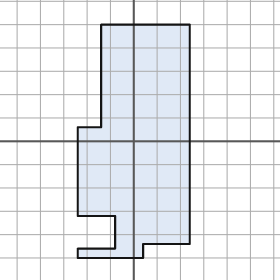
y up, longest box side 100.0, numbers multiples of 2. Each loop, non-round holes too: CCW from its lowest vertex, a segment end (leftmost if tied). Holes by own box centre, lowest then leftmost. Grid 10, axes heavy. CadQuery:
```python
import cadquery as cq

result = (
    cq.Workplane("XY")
    .moveTo(-24.0, -50.0)
    .lineTo(4.0, -50.0)
    .lineTo(4.0, -44.0)
    .lineTo(24.0, -44.0)
    .lineTo(24.0, 50.0)
    .lineTo(-14.0, 50.0)
    .lineTo(-14.0, 6.0)
    .lineTo(-24.0, 6.0)
    .lineTo(-24.0, -32.0)
    .lineTo(-8.0, -32.0)
    .lineTo(-8.0, -46.0)
    .lineTo(-24.0, -46.0)
    .close()
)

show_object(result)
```